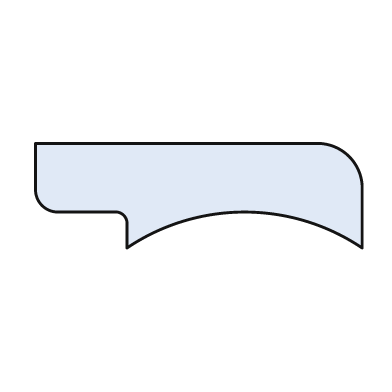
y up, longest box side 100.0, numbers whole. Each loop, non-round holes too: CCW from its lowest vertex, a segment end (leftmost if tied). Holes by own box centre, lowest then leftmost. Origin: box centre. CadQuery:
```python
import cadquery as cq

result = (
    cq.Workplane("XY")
    .moveTo(-22.0, -16.0)
    .threePointArc((14.0, -5.0), (50.0, -16.0))
    .lineTo(50.0, 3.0)
    .threePointArc((46.0, 12.0), (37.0, 16.0))
    .lineTo(-50.0, 16.0)
    .lineTo(-50.0, 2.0)
    .threePointArc((-48.0, -3.0), (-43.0, -5.0))
    .lineTo(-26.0, -5.0)
    .threePointArc((-23.0, -6.0), (-22.0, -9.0))
    .close()
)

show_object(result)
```